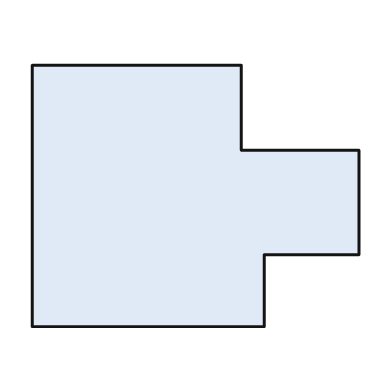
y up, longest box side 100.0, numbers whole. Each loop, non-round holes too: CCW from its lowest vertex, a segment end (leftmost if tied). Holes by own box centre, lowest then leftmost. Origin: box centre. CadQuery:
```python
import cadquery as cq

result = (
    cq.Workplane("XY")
    .moveTo(-50.0, -40.0)
    .lineTo(21.0, -40.0)
    .lineTo(21.0, -18.0)
    .lineTo(50.0, -18.0)
    .lineTo(50.0, 14.0)
    .lineTo(14.0, 14.0)
    .lineTo(14.0, 40.0)
    .lineTo(-50.0, 40.0)
    .close()
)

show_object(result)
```